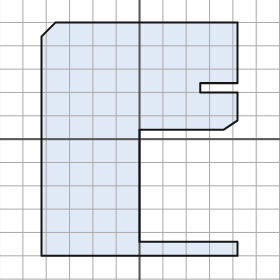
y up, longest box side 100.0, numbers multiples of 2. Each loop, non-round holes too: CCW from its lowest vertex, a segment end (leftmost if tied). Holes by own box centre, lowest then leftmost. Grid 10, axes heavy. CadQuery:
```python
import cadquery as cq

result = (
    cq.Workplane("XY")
    .moveTo(-42.0, -50.0)
    .lineTo(42.0, -50.0)
    .lineTo(42.0, -44.0)
    .lineTo(0.0, -44.0)
    .lineTo(0.0, 4.0)
    .lineTo(36.0, 4.0)
    .lineTo(42.0, 8.0)
    .lineTo(42.0, 20.0)
    .lineTo(26.0, 20.0)
    .lineTo(26.0, 24.0)
    .lineTo(42.0, 24.0)
    .lineTo(42.0, 50.0)
    .lineTo(-36.0, 50.0)
    .lineTo(-42.0, 44.0)
    .close()
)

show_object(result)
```